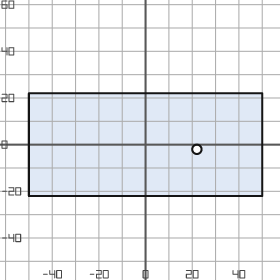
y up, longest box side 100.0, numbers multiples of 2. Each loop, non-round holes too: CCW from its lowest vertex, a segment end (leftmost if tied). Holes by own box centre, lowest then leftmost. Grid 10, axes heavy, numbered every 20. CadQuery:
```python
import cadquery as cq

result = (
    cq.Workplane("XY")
    .moveTo(-50.0, -22.0)
    .lineTo(50.0, -22.0)
    .lineTo(50.0, 22.0)
    .lineTo(-50.0, 22.0)
    .close()
    .moveTo(22.0, -2.0)
    .circle(2.0)
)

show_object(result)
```